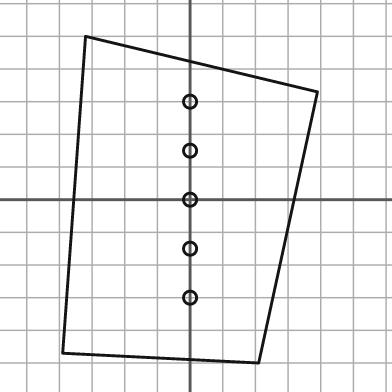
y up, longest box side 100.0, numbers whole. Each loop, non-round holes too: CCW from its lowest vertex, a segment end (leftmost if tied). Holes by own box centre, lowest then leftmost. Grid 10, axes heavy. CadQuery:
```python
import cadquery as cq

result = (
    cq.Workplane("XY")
    .moveTo(21.0, -50.0)
    .lineTo(39.0, 33.0)
    .lineTo(-32.0, 50.0)
    .lineTo(-39.0, -47.0)
    .close()
    .moveTo(0.0, -30.0)
    .circle(2.0)
    .moveTo(0.0, -15.0)
    .circle(2.0)
    .moveTo(0.0, 0.0)
    .circle(2.0)
    .moveTo(0.0, 15.0)
    .circle(2.0)
    .moveTo(0.0, 30.0)
    .circle(2.0)
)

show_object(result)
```